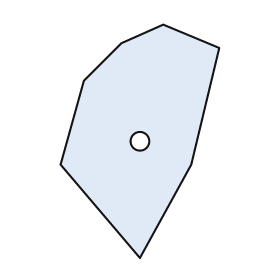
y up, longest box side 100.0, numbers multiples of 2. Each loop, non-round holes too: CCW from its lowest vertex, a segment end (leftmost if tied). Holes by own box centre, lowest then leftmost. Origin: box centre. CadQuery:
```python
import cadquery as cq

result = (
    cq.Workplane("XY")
    .moveTo(0.0, -50.0)
    .lineTo(22.0, -10.0)
    .lineTo(34.0, 40.0)
    .lineTo(10.0, 50.0)
    .lineTo(-8.0, 42.0)
    .lineTo(-24.0, 26.0)
    .lineTo(-34.0, -10.0)
    .close()
    .moveTo(0.0, 0.0)
    .circle(4.0)
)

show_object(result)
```